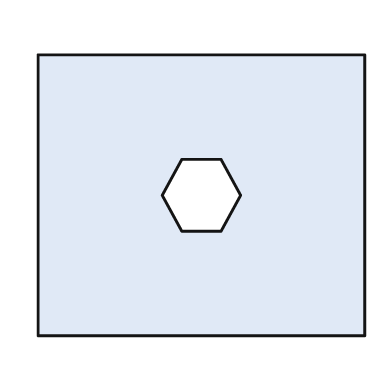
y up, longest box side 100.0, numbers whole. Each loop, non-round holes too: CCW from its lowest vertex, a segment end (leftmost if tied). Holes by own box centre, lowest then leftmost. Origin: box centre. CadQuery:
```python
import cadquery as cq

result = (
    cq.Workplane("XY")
    .moveTo(-50.0, -43.0)
    .lineTo(50.0, -43.0)
    .lineTo(50.0, 43.0)
    .lineTo(-50.0, 43.0)
    .close()
    .moveTo(-6.0, -11.0)
    .lineTo(6.0, -11.0)
    .lineTo(12.0, 0.0)
    .lineTo(6.0, 11.0)
    .lineTo(-6.0, 11.0)
    .lineTo(-12.0, 0.0)
    .close()
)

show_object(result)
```